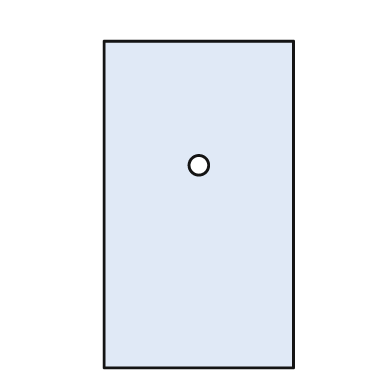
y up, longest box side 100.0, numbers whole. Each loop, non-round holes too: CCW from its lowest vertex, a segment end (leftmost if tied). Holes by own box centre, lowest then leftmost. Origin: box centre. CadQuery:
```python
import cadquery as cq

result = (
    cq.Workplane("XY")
    .moveTo(-29.0, -50.0)
    .lineTo(29.0, -50.0)
    .lineTo(29.0, 50.0)
    .lineTo(-29.0, 50.0)
    .close()
    .moveTo(0.0, 12.0)
    .circle(3.0)
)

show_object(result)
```